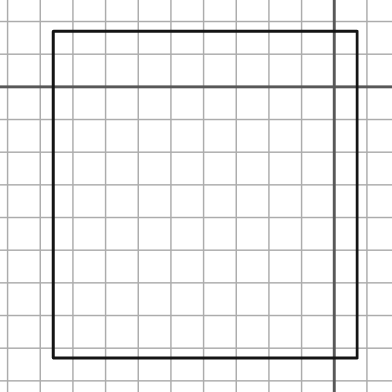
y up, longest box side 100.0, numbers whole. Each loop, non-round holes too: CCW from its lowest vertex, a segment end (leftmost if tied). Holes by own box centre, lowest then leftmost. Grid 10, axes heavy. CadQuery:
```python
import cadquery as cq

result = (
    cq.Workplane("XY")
    .moveTo(-86.0, -83.0)
    .lineTo(7.0, -83.0)
    .lineTo(7.0, 17.0)
    .lineTo(-86.0, 17.0)
    .close()
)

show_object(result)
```